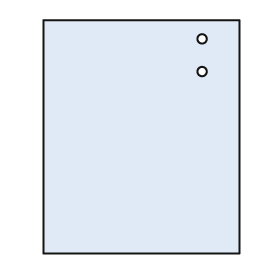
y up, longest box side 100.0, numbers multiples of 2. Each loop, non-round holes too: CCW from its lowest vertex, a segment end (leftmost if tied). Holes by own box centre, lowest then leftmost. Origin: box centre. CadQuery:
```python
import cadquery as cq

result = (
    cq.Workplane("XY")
    .moveTo(-42.0, -50.0)
    .lineTo(42.0, -50.0)
    .lineTo(42.0, 50.0)
    .lineTo(-42.0, 50.0)
    .close()
    .moveTo(26.0, 28.0)
    .circle(2.0)
    .moveTo(26.0, 42.0)
    .circle(2.0)
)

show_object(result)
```